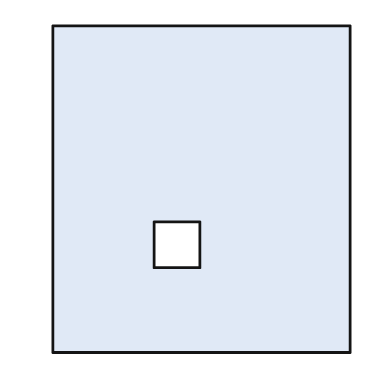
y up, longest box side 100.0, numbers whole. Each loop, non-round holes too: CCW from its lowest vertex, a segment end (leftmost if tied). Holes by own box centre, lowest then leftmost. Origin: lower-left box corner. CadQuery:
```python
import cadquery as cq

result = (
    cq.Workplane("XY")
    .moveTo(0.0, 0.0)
    .lineTo(91.0, 0.0)
    .lineTo(91.0, 100.0)
    .lineTo(0.0, 100.0)
    .close()
    .moveTo(31.0, 26.0)
    .lineTo(45.0, 26.0)
    .lineTo(45.0, 40.0)
    .lineTo(31.0, 40.0)
    .close()
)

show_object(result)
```